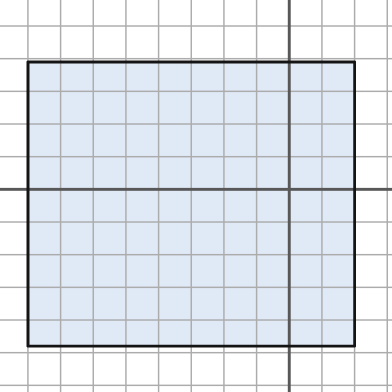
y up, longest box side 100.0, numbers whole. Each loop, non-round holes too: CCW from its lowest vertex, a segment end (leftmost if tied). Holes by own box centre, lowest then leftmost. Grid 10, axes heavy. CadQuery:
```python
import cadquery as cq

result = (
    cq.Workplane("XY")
    .moveTo(-80.0, -48.0)
    .lineTo(20.0, -48.0)
    .lineTo(20.0, 39.0)
    .lineTo(-80.0, 39.0)
    .close()
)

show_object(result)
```